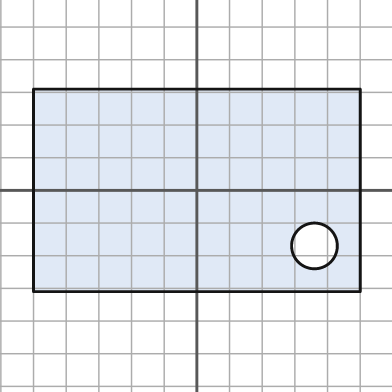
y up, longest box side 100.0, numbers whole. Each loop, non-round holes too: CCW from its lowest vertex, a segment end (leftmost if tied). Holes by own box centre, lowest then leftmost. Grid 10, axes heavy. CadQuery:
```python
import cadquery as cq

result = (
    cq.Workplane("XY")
    .moveTo(-50.0, -31.0)
    .lineTo(50.0, -31.0)
    .lineTo(50.0, 31.0)
    .lineTo(-50.0, 31.0)
    .close()
    .moveTo(36.0, -17.0)
    .circle(7.0)
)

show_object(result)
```